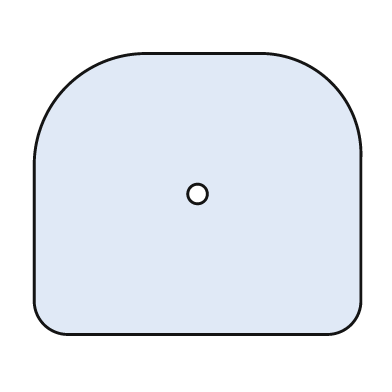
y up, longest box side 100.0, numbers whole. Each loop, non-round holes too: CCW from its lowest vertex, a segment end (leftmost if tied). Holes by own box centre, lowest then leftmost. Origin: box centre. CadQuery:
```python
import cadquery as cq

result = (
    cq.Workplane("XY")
    .moveTo(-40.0, -43.0)
    .lineTo(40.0, -43.0)
    .threePointArc((47.0, -40.0), (50.0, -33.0))
    .lineTo(50.0, 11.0)
    .threePointArc((41.0, 34.0), (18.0, 43.0))
    .lineTo(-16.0, 43.0)
    .threePointArc((-40.0, 33.0), (-50.0, 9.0))
    .lineTo(-50.0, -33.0)
    .threePointArc((-47.0, -40.0), (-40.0, -43.0))
    .close()
    .moveTo(0.0, 0.0)
    .circle(3.0)
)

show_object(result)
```